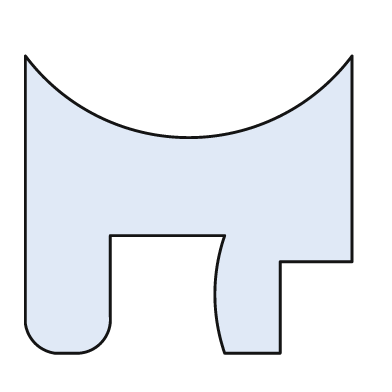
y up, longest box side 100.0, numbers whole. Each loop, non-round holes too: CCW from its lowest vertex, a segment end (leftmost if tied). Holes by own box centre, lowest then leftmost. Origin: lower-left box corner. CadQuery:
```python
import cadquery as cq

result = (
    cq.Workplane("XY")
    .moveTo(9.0, 0.0)
    .lineTo(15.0, 0.0)
    .threePointArc((23.0, 3.0), (26.0, 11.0))
    .lineTo(26.0, 36.0)
    .lineTo(61.0, 36.0)
    .threePointArc((58.0, 18.0), (61.0, 0.0))
    .lineTo(78.0, 0.0)
    .lineTo(78.0, 28.0)
    .lineTo(100.0, 28.0)
    .lineTo(100.0, 91.0)
    .threePointArc((50.0, 66.0), (0.0, 91.0))
    .lineTo(0.0, 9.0)
    .threePointArc((3.0, 3.0), (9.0, 0.0))
    .close()
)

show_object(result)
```